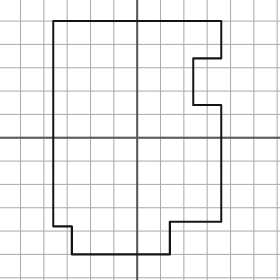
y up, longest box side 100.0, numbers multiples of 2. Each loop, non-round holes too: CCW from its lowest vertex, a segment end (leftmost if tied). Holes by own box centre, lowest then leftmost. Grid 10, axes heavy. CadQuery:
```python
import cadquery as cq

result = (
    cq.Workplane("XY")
    .moveTo(-28.0, -50.0)
    .lineTo(14.0, -50.0)
    .lineTo(14.0, -36.0)
    .lineTo(36.0, -36.0)
    .lineTo(36.0, 14.0)
    .lineTo(24.0, 14.0)
    .lineTo(24.0, 34.0)
    .lineTo(36.0, 34.0)
    .lineTo(36.0, 50.0)
    .lineTo(-36.0, 50.0)
    .lineTo(-36.0, -38.0)
    .lineTo(-28.0, -38.0)
    .close()
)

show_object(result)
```